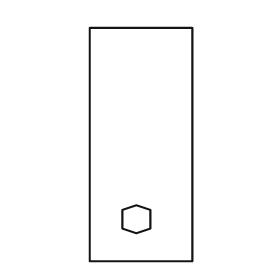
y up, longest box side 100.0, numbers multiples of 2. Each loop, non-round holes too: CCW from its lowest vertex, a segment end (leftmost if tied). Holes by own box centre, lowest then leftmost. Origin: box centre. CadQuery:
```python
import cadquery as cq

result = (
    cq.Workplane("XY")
    .moveTo(-22.0, -50.0)
    .lineTo(22.0, -50.0)
    .lineTo(22.0, 50.0)
    .lineTo(-22.0, 50.0)
    .close()
    .moveTo(-2.0, -38.0)
    .lineTo(4.0, -36.0)
    .lineTo(4.0, -28.0)
    .lineTo(-2.0, -26.0)
    .lineTo(-8.0, -28.0)
    .lineTo(-8.0, -36.0)
    .close()
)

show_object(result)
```